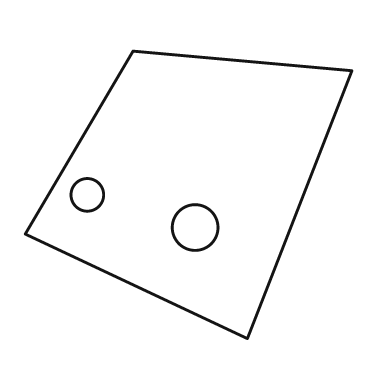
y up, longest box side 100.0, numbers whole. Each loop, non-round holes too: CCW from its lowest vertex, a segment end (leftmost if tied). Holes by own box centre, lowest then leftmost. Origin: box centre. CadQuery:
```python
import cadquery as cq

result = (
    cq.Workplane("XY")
    .moveTo(18.0, -44.0)
    .lineTo(50.0, 38.0)
    .lineTo(-17.0, 44.0)
    .lineTo(-50.0, -12.0)
    .close()
    .moveTo(2.0, -10.0)
    .circle(7.0)
    .moveTo(-31.0, 0.0)
    .circle(5.0)
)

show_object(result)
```